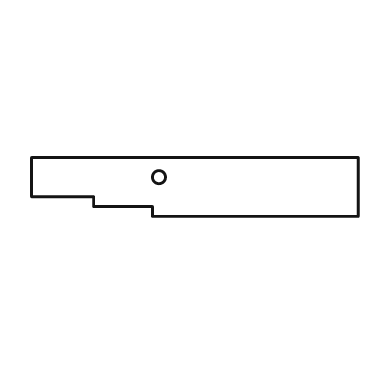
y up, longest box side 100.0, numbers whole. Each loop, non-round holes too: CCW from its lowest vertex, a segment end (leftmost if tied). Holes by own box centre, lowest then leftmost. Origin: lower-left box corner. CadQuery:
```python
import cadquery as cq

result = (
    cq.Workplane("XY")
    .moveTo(37.0, 0.0)
    .lineTo(100.0, 0.0)
    .lineTo(100.0, 18.0)
    .lineTo(0.0, 18.0)
    .lineTo(0.0, 6.0)
    .lineTo(19.0, 6.0)
    .lineTo(19.0, 3.0)
    .lineTo(37.0, 3.0)
    .close()
    .moveTo(39.0, 12.0)
    .circle(2.0)
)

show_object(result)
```